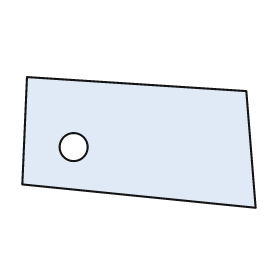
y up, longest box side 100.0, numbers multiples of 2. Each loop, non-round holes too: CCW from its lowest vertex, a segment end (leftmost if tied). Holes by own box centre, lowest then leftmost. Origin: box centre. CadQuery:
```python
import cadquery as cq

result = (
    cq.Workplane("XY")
    .moveTo(50.0, -28.0)
    .lineTo(46.0, 22.0)
    .lineTo(-48.0, 28.0)
    .lineTo(-50.0, -18.0)
    .close()
    .moveTo(-28.0, -2.0)
    .circle(6.0)
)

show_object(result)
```